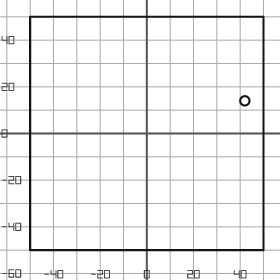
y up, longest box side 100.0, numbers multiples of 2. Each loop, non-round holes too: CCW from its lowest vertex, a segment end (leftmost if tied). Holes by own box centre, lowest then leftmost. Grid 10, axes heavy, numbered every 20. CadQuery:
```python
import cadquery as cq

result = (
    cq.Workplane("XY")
    .moveTo(-50.0, -50.0)
    .lineTo(50.0, -50.0)
    .lineTo(50.0, 50.0)
    .lineTo(-50.0, 50.0)
    .close()
    .moveTo(42.0, 14.0)
    .circle(2.0)
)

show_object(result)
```